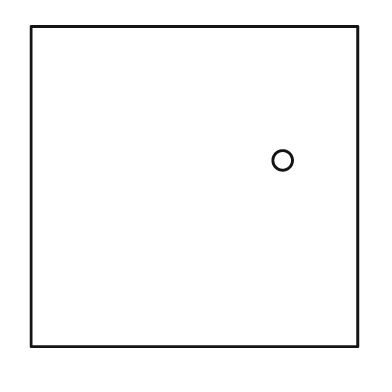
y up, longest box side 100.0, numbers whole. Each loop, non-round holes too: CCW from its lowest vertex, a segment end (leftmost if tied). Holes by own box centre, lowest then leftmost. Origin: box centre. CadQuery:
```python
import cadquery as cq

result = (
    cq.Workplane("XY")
    .moveTo(-50.0, -49.0)
    .lineTo(50.0, -49.0)
    .lineTo(50.0, 49.0)
    .lineTo(-50.0, 49.0)
    .close()
    .moveTo(27.0, 8.0)
    .circle(3.0)
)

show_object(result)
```